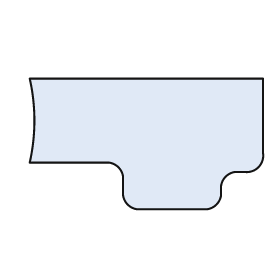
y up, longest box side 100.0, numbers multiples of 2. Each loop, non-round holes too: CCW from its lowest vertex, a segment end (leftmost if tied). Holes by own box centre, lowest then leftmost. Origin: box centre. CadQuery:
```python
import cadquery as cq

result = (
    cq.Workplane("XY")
    .moveTo(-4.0, -28.0)
    .lineTo(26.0, -28.0)
    .threePointArc((30.0, -26.0), (32.0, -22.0))
    .lineTo(32.0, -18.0)
    .threePointArc((34.0, -14.0), (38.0, -12.0))
    .lineTo(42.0, -12.0)
    .threePointArc((48.0, -10.0), (50.0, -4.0))
    .lineTo(50.0, 28.0)
    .lineTo(-50.0, 28.0)
    .threePointArc((-48.0, 10.0), (-50.0, -8.0))
    .lineTo(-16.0, -8.0)
    .threePointArc((-12.0, -10.0), (-10.0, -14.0))
    .lineTo(-10.0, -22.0)
    .threePointArc((-8.0, -26.0), (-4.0, -28.0))
    .close()
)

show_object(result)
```